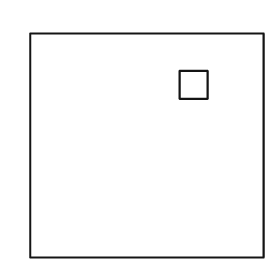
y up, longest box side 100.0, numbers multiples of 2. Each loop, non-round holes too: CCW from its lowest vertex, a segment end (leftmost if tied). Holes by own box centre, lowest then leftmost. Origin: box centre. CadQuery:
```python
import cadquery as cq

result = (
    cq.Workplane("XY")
    .moveTo(-50.0, -48.0)
    .lineTo(50.0, -48.0)
    .lineTo(50.0, 48.0)
    .lineTo(-50.0, 48.0)
    .close()
    .moveTo(14.0, 20.0)
    .lineTo(26.0, 20.0)
    .lineTo(26.0, 32.0)
    .lineTo(14.0, 32.0)
    .close()
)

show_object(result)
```